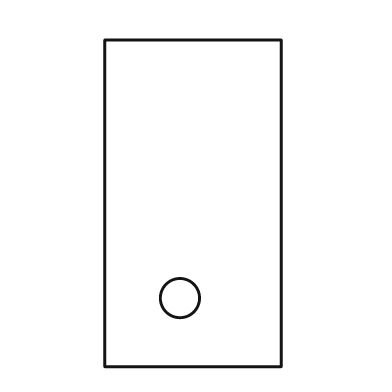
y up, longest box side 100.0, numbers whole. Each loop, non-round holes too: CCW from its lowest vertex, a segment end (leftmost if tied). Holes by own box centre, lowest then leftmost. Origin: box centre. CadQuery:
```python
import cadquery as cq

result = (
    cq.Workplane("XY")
    .moveTo(-27.0, -50.0)
    .lineTo(27.0, -50.0)
    .lineTo(27.0, 50.0)
    .lineTo(-27.0, 50.0)
    .close()
    .moveTo(-4.0, -29.0)
    .circle(6.0)
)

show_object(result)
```